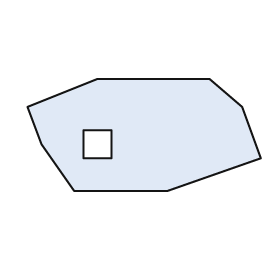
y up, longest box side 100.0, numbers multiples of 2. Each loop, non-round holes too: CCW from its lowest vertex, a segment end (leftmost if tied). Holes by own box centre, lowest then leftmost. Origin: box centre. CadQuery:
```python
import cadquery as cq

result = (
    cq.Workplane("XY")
    .moveTo(-30.0, -24.0)
    .lineTo(10.0, -24.0)
    .lineTo(50.0, -10.0)
    .lineTo(42.0, 12.0)
    .lineTo(28.0, 24.0)
    .lineTo(-20.0, 24.0)
    .lineTo(-50.0, 12.0)
    .lineTo(-44.0, -4.0)
    .close()
    .moveTo(-26.0, -10.0)
    .lineTo(-14.0, -10.0)
    .lineTo(-14.0, 2.0)
    .lineTo(-26.0, 2.0)
    .close()
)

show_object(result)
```